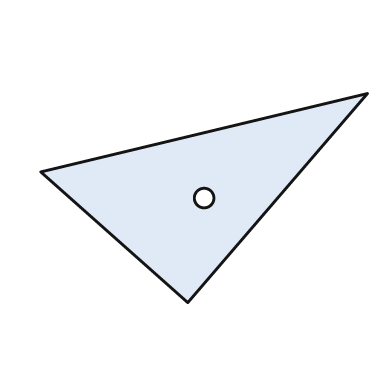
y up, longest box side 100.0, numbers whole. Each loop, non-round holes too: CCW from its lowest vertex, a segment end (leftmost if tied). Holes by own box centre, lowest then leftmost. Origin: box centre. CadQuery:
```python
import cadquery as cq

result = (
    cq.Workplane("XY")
    .moveTo(-5.0, -32.0)
    .lineTo(50.0, 32.0)
    .lineTo(-50.0, 8.0)
    .close()
    .moveTo(0.0, 0.0)
    .circle(3.0)
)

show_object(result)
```